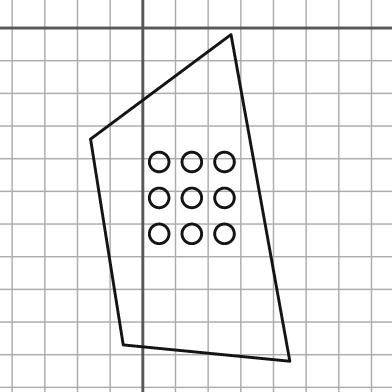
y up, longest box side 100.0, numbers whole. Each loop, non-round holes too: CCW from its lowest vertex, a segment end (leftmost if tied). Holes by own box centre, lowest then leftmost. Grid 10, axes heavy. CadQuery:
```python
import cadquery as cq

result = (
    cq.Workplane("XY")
    .moveTo(45.0, -102.0)
    .lineTo(27.0, -2.0)
    .lineTo(-16.0, -34.0)
    .lineTo(-6.0, -97.0)
    .close()
    .moveTo(5.0, -63.0)
    .circle(3.0)
    .moveTo(15.0, -63.0)
    .circle(3.0)
    .moveTo(25.0, -63.0)
    .circle(3.0)
    .moveTo(5.0, -52.0)
    .circle(3.0)
    .moveTo(15.0, -52.0)
    .circle(3.0)
    .moveTo(25.0, -52.0)
    .circle(3.0)
    .moveTo(5.0, -41.0)
    .circle(3.0)
    .moveTo(15.0, -41.0)
    .circle(3.0)
    .moveTo(25.0, -41.0)
    .circle(3.0)
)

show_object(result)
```